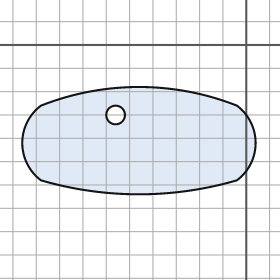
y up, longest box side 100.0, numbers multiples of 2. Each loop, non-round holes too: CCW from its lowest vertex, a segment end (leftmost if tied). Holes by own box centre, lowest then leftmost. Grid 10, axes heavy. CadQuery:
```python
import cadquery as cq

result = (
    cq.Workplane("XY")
    .moveTo(-88.0, -58.0)
    .threePointArc((-46.0, -64.0), (-4.0, -58.0))
    .threePointArc((4.0, -42.0), (-4.0, -26.0))
    .threePointArc((-46.0, -18.0), (-88.0, -26.0))
    .threePointArc((-96.0, -42.0), (-88.0, -58.0))
    .close()
    .moveTo(-56.0, -30.0)
    .circle(4.0)
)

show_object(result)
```